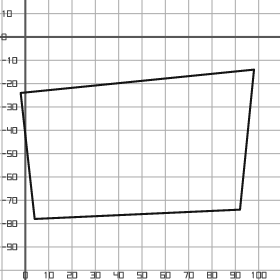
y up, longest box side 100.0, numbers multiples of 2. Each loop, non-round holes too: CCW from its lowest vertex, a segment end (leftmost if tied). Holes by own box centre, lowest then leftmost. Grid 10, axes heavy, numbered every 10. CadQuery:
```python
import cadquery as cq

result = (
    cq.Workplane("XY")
    .moveTo(4.0, -78.0)
    .lineTo(92.0, -74.0)
    .lineTo(98.0, -14.0)
    .lineTo(-2.0, -24.0)
    .close()
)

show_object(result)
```